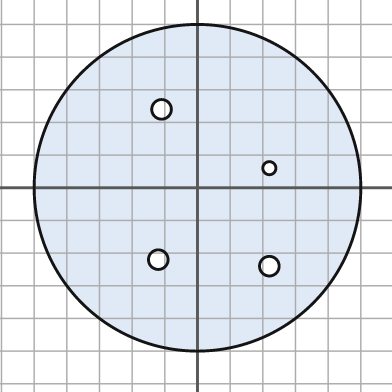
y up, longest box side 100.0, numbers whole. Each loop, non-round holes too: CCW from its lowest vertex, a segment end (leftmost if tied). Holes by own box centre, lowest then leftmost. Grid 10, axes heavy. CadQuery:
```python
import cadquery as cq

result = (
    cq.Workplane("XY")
    .moveTo(0.0, 0.0)
    .circle(50.0)
    .moveTo(22.0, -24.0)
    .circle(3.0)
    .moveTo(-12.0, -22.0)
    .circle(3.0)
    .moveTo(22.0, 6.0)
    .circle(2.0)
    .moveTo(-11.0, 24.0)
    .circle(3.0)
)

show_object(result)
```